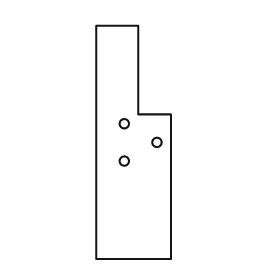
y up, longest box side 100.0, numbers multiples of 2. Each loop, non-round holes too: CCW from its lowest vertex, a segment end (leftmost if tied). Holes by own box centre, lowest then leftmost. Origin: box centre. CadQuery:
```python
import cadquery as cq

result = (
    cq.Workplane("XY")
    .moveTo(-16.0, -50.0)
    .lineTo(16.0, -50.0)
    .lineTo(16.0, 12.0)
    .lineTo(2.0, 12.0)
    .lineTo(2.0, 50.0)
    .lineTo(-16.0, 50.0)
    .close()
    .moveTo(-4.0, -8.0)
    .circle(2.0)
    .moveTo(10.0, 0.0)
    .circle(2.0)
    .moveTo(-4.0, 8.0)
    .circle(2.0)
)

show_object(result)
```